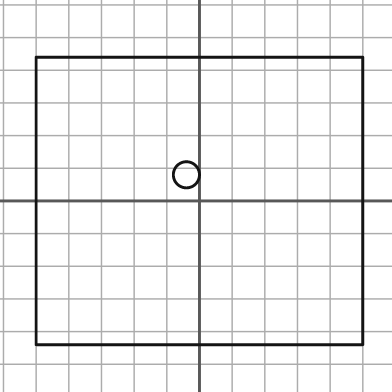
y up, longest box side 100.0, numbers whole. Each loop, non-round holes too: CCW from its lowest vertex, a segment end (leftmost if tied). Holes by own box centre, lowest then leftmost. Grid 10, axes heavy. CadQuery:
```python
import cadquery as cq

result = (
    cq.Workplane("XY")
    .moveTo(-50.0, -44.0)
    .lineTo(50.0, -44.0)
    .lineTo(50.0, 44.0)
    .lineTo(-50.0, 44.0)
    .close()
    .moveTo(-4.0, 8.0)
    .circle(4.0)
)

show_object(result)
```